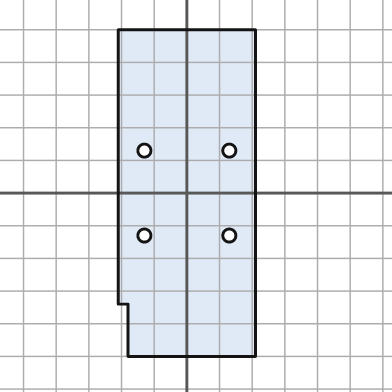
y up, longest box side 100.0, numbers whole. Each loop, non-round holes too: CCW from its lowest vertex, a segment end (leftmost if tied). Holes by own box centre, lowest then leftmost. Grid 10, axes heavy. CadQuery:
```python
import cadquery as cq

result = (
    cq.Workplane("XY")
    .moveTo(-18.0, -50.0)
    .lineTo(21.0, -50.0)
    .lineTo(21.0, 50.0)
    .lineTo(-21.0, 50.0)
    .lineTo(-21.0, -34.0)
    .lineTo(-18.0, -34.0)
    .close()
    .moveTo(-13.0, -13.0)
    .circle(2.0)
    .moveTo(13.0, -13.0)
    .circle(2.0)
    .moveTo(-13.0, 13.0)
    .circle(2.0)
    .moveTo(13.0, 13.0)
    .circle(2.0)
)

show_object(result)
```